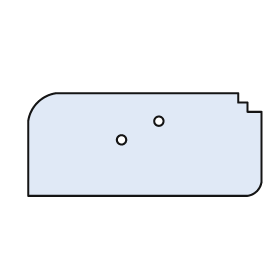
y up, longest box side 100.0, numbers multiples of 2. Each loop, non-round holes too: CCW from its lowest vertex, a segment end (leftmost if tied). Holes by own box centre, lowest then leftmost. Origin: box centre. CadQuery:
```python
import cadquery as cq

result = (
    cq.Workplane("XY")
    .moveTo(-50.0, -22.0)
    .lineTo(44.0, -22.0)
    .threePointArc((48.0, -20.0), (50.0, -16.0))
    .lineTo(50.0, 14.0)
    .lineTo(44.0, 14.0)
    .lineTo(44.0, 18.0)
    .lineTo(40.0, 18.0)
    .lineTo(40.0, 22.0)
    .lineTo(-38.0, 22.0)
    .threePointArc((-46.0, 18.0), (-50.0, 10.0))
    .close()
    .moveTo(-10.0, 2.0)
    .circle(2.0)
    .moveTo(6.0, 10.0)
    .circle(2.0)
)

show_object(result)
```